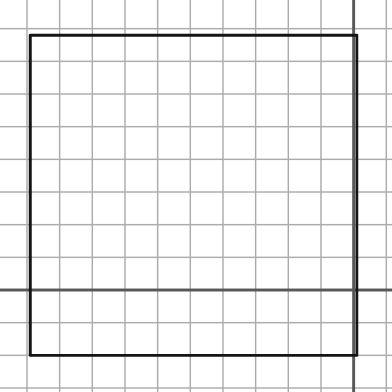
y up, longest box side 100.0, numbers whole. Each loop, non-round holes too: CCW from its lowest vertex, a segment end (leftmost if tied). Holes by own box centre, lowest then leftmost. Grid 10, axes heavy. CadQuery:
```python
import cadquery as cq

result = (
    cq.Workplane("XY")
    .moveTo(-99.0, -20.0)
    .lineTo(1.0, -20.0)
    .lineTo(1.0, 78.0)
    .lineTo(-99.0, 78.0)
    .close()
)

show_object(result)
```